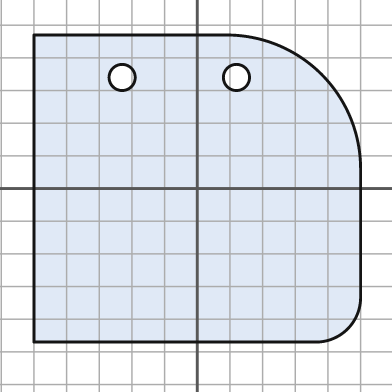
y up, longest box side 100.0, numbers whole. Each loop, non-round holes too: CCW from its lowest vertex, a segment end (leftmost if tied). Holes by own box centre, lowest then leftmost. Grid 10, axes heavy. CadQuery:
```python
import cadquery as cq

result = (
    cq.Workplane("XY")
    .moveTo(-50.0, -47.0)
    .lineTo(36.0, -47.0)
    .threePointArc((46.0, -43.0), (50.0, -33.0))
    .lineTo(50.0, 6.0)
    .threePointArc((38.0, 35.0), (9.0, 47.0))
    .lineTo(-50.0, 47.0)
    .close()
    .moveTo(-23.0, 34.0)
    .circle(4.0)
    .moveTo(12.0, 34.0)
    .circle(4.0)
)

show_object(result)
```